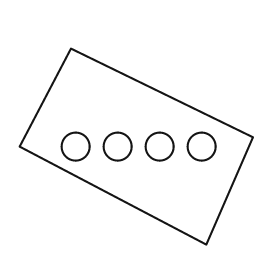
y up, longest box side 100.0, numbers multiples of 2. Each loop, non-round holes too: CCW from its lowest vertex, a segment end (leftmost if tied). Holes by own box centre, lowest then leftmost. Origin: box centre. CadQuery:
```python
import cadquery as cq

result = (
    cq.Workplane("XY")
    .moveTo(30.0, -42.0)
    .lineTo(50.0, 4.0)
    .lineTo(-28.0, 42.0)
    .lineTo(-50.0, 0.0)
    .close()
    .moveTo(-26.0, 0.0)
    .circle(6.0)
    .moveTo(-8.0, 0.0)
    .circle(6.0)
    .moveTo(10.0, 0.0)
    .circle(6.0)
    .moveTo(28.0, 0.0)
    .circle(6.0)
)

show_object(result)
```